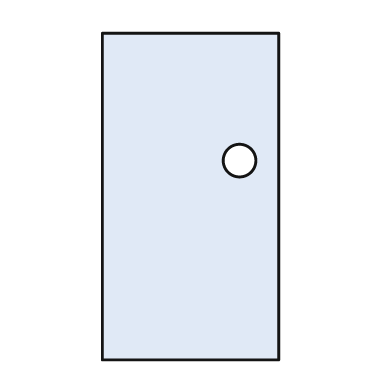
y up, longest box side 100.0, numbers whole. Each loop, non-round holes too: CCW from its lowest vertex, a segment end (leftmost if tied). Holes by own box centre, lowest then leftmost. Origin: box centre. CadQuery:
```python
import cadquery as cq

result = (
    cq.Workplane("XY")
    .moveTo(-27.0, -50.0)
    .lineTo(27.0, -50.0)
    .lineTo(27.0, 50.0)
    .lineTo(-27.0, 50.0)
    .close()
    .moveTo(15.0, 11.0)
    .circle(5.0)
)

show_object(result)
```